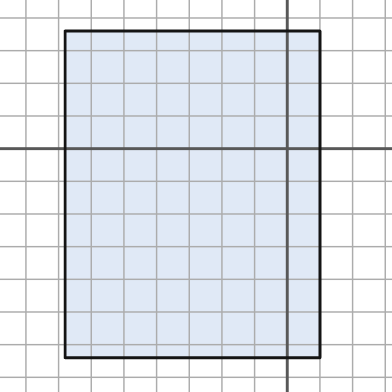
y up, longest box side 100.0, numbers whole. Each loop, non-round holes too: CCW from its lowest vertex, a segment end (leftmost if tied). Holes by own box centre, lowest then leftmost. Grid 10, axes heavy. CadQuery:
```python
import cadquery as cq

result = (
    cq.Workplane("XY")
    .moveTo(-68.0, -64.0)
    .lineTo(10.0, -64.0)
    .lineTo(10.0, 36.0)
    .lineTo(-68.0, 36.0)
    .close()
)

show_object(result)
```